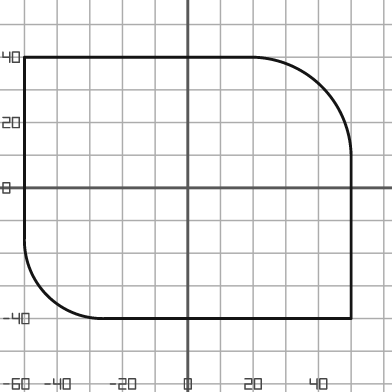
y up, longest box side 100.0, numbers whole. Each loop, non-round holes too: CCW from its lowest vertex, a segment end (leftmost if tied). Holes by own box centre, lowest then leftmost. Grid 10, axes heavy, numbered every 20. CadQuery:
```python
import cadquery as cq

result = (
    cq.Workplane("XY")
    .moveTo(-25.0, -40.0)
    .lineTo(50.0, -40.0)
    .lineTo(50.0, 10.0)
    .threePointArc((41.0, 31.0), (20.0, 40.0))
    .lineTo(-50.0, 40.0)
    .lineTo(-50.0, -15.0)
    .threePointArc((-43.0, -33.0), (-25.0, -40.0))
    .close()
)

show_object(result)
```